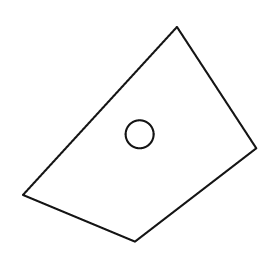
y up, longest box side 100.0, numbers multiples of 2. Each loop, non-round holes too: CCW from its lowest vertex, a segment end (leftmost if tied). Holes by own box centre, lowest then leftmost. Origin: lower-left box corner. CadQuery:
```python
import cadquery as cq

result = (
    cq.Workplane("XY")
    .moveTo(48.0, 0.0)
    .lineTo(100.0, 40.0)
    .lineTo(66.0, 92.0)
    .lineTo(0.0, 20.0)
    .close()
    .moveTo(50.0, 46.0)
    .circle(6.0)
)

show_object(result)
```